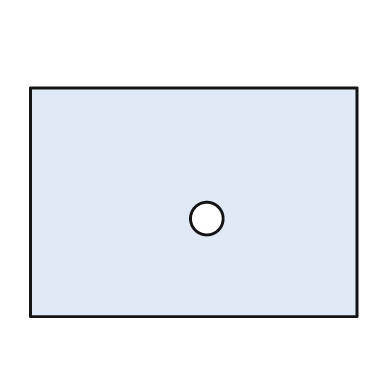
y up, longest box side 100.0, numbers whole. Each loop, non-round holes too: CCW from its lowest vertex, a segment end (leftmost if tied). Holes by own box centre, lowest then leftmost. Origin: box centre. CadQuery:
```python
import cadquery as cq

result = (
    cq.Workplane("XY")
    .moveTo(-50.0, -35.0)
    .lineTo(50.0, -35.0)
    .lineTo(50.0, 35.0)
    .lineTo(-50.0, 35.0)
    .close()
    .moveTo(4.0, -5.0)
    .circle(5.0)
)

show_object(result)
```